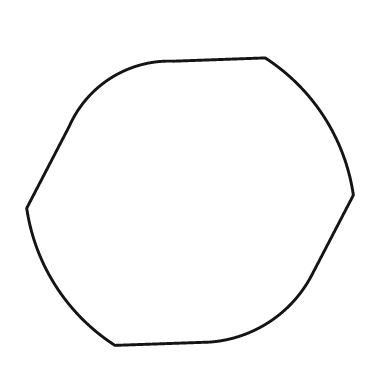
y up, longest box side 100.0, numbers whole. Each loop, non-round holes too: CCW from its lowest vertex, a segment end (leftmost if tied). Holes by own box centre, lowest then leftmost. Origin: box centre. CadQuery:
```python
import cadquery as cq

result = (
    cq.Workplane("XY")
    .moveTo(-23.0, -44.0)
    .lineTo(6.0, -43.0)
    .threePointArc((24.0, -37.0), (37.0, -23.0))
    .lineTo(50.0, 2.0)
    .threePointArc((41.0, 26.0), (23.0, 44.0))
    .lineTo(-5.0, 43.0)
    .threePointArc((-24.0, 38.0), (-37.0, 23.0))
    .lineTo(-50.0, -2.0)
    .threePointArc((-41.0, -26.0), (-23.0, -44.0))
    .close()
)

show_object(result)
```